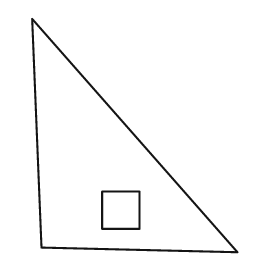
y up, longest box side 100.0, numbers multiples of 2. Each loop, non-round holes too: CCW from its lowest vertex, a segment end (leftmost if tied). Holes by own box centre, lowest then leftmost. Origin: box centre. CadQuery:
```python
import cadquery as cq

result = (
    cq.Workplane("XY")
    .moveTo(44.0, -50.0)
    .lineTo(-44.0, 50.0)
    .lineTo(-40.0, -48.0)
    .close()
    .moveTo(-14.0, -40.0)
    .lineTo(2.0, -40.0)
    .lineTo(2.0, -24.0)
    .lineTo(-14.0, -24.0)
    .close()
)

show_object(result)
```